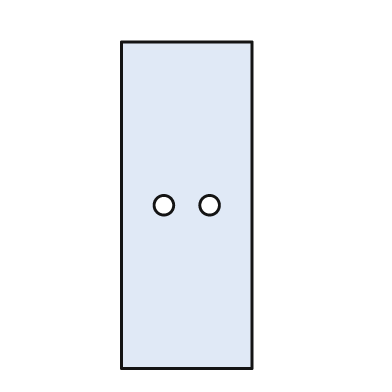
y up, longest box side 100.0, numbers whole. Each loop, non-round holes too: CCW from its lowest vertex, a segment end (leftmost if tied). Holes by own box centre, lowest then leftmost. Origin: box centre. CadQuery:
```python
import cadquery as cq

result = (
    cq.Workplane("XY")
    .moveTo(-20.0, -50.0)
    .lineTo(20.0, -50.0)
    .lineTo(20.0, 50.0)
    .lineTo(-20.0, 50.0)
    .close()
    .moveTo(-7.0, 0.0)
    .circle(3.0)
    .moveTo(7.0, 0.0)
    .circle(3.0)
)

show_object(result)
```